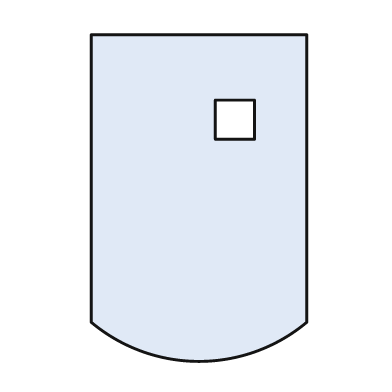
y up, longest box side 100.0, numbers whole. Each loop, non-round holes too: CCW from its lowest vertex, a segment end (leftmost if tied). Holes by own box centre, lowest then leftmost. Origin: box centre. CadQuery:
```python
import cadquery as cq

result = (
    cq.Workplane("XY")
    .moveTo(-33.0, -38.0)
    .threePointArc((0.0, -50.0), (33.0, -38.0))
    .lineTo(33.0, 50.0)
    .lineTo(-33.0, 50.0)
    .close()
    .moveTo(5.0, 18.0)
    .lineTo(17.0, 18.0)
    .lineTo(17.0, 30.0)
    .lineTo(5.0, 30.0)
    .close()
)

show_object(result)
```